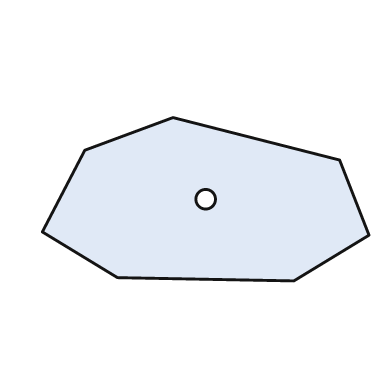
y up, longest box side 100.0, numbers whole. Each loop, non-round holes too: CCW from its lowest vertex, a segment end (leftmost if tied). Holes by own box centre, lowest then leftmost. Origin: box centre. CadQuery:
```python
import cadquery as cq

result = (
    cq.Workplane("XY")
    .moveTo(27.0, -25.0)
    .lineTo(50.0, -11.0)
    .lineTo(41.0, 12.0)
    .lineTo(-10.0, 25.0)
    .lineTo(-37.0, 15.0)
    .lineTo(-50.0, -10.0)
    .lineTo(-27.0, -24.0)
    .close()
    .moveTo(0.0, 0.0)
    .circle(3.0)
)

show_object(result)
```